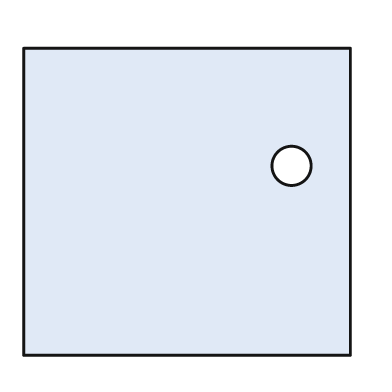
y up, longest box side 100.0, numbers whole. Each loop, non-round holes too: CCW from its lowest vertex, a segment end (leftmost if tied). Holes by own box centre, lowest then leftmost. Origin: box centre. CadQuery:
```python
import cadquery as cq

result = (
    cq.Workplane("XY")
    .moveTo(-50.0, -47.0)
    .lineTo(50.0, -47.0)
    .lineTo(50.0, 47.0)
    .lineTo(-50.0, 47.0)
    .close()
    .moveTo(32.0, 11.0)
    .circle(6.0)
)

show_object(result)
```